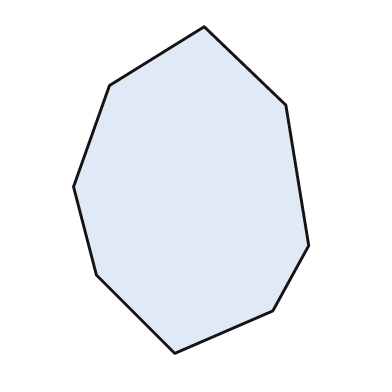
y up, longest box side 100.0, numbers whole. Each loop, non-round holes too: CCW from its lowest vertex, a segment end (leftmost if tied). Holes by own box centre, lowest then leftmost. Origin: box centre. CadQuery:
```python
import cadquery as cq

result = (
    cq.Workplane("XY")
    .moveTo(-5.0, -50.0)
    .lineTo(25.0, -37.0)
    .lineTo(36.0, -17.0)
    .lineTo(29.0, 26.0)
    .lineTo(4.0, 50.0)
    .lineTo(-25.0, 32.0)
    .lineTo(-36.0, 1.0)
    .lineTo(-29.0, -26.0)
    .close()
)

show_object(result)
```